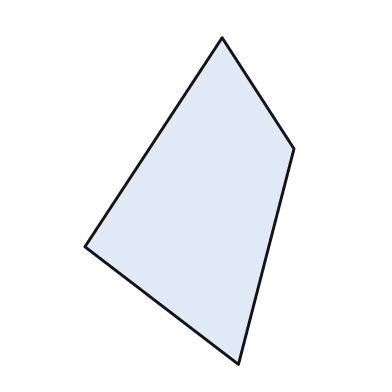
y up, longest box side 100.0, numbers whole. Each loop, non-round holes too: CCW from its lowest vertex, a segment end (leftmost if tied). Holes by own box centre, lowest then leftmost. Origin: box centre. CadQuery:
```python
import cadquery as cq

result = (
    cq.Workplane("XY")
    .moveTo(15.0, -50.0)
    .lineTo(32.0, 16.0)
    .lineTo(10.0, 50.0)
    .lineTo(-32.0, -14.0)
    .close()
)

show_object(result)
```